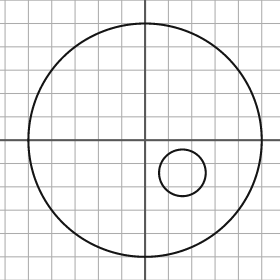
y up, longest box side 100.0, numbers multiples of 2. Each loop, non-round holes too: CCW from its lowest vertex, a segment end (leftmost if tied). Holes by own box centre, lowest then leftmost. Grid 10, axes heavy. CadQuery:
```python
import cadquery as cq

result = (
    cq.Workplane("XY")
    .moveTo(0.0, 0.0)
    .circle(50.0)
    .moveTo(16.0, -14.0)
    .circle(10.0)
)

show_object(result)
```